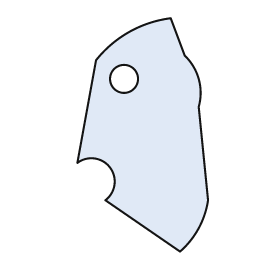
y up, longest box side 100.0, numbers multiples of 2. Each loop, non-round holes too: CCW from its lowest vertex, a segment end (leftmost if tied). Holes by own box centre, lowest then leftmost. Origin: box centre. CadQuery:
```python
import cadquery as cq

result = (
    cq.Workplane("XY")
    .moveTo(16.0, -50.0)
    .threePointArc((24.0, -40.0), (28.0, -28.0))
    .lineTo(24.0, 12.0)
    .threePointArc((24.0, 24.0), (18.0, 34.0))
    .lineTo(12.0, 50.0)
    .threePointArc((-6.0, 44.0), (-20.0, 32.0))
    .lineTo(-28.0, -12.0)
    .threePointArc((-14.0, -14.0), (-16.0, -28.0))
    .close()
    .moveTo(-8.0, 24.0)
    .circle(6.0)
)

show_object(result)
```